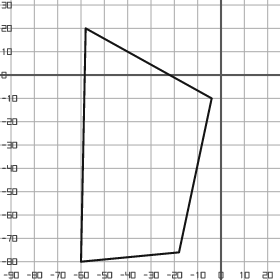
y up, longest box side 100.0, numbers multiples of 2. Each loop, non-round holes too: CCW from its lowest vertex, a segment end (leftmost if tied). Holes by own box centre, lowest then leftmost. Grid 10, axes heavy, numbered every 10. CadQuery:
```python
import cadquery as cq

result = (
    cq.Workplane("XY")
    .moveTo(-60.0, -80.0)
    .lineTo(-18.0, -76.0)
    .lineTo(-4.0, -10.0)
    .lineTo(-58.0, 20.0)
    .close()
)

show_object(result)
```